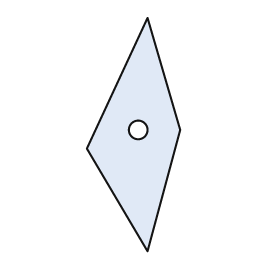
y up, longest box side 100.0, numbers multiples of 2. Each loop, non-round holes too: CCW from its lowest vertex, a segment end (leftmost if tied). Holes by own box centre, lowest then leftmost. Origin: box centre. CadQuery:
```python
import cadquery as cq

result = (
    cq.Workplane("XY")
    .moveTo(6.0, -50.0)
    .lineTo(20.0, 2.0)
    .lineTo(6.0, 50.0)
    .lineTo(-20.0, -6.0)
    .close()
    .moveTo(2.0, 2.0)
    .circle(4.0)
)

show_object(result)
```